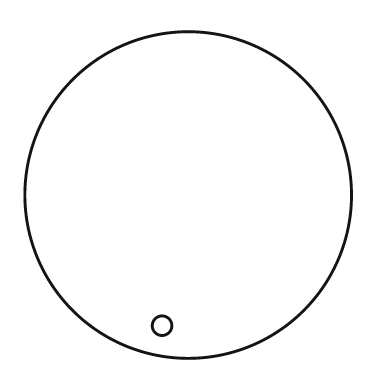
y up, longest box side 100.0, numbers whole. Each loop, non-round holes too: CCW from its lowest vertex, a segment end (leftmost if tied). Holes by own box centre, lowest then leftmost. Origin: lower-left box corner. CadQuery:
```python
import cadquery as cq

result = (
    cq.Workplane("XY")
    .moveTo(50.0, 50.0)
    .circle(50.0)
    .moveTo(42.0, 10.0)
    .circle(3.0)
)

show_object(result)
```